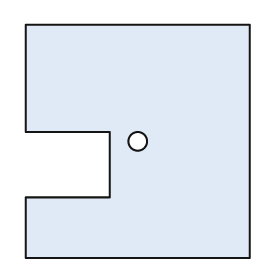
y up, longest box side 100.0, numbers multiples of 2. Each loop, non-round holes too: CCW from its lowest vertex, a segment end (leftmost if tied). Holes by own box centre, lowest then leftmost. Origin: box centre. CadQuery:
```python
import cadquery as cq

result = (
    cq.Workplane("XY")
    .moveTo(-48.0, -50.0)
    .lineTo(48.0, -50.0)
    .lineTo(48.0, 50.0)
    .lineTo(-48.0, 50.0)
    .lineTo(-48.0, 4.0)
    .lineTo(-12.0, 4.0)
    .lineTo(-12.0, -24.0)
    .lineTo(-48.0, -24.0)
    .close()
    .moveTo(0.0, 0.0)
    .circle(4.0)
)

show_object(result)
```